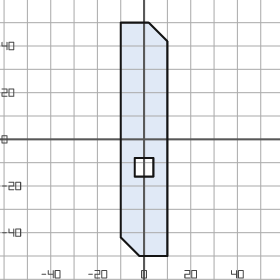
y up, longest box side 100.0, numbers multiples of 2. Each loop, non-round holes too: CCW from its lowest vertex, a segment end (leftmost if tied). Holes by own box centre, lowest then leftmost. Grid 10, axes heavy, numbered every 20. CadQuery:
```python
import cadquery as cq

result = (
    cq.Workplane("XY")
    .moveTo(-2.0, -50.0)
    .lineTo(10.0, -50.0)
    .lineTo(10.0, 42.0)
    .lineTo(2.0, 50.0)
    .lineTo(-10.0, 50.0)
    .lineTo(-10.0, -42.0)
    .close()
    .moveTo(-4.0, -16.0)
    .lineTo(4.0, -16.0)
    .lineTo(4.0, -8.0)
    .lineTo(-4.0, -8.0)
    .close()
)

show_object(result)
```